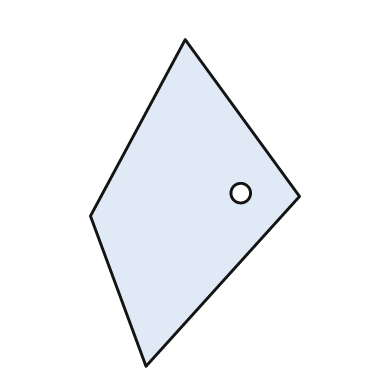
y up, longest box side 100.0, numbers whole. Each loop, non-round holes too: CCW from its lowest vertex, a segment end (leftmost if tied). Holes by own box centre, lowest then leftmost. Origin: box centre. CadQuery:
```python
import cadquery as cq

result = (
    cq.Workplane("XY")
    .moveTo(-15.0, -50.0)
    .lineTo(32.0, 2.0)
    .lineTo(-3.0, 50.0)
    .lineTo(-32.0, -4.0)
    .close()
    .moveTo(14.0, 3.0)
    .circle(3.0)
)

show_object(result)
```